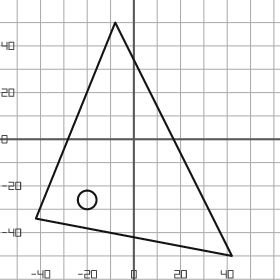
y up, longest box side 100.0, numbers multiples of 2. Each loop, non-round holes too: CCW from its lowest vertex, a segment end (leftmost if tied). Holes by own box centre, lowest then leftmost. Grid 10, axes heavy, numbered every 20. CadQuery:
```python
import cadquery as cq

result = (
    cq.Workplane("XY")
    .moveTo(42.0, -50.0)
    .lineTo(-8.0, 50.0)
    .lineTo(-42.0, -34.0)
    .close()
    .moveTo(-20.0, -26.0)
    .circle(4.0)
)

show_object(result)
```